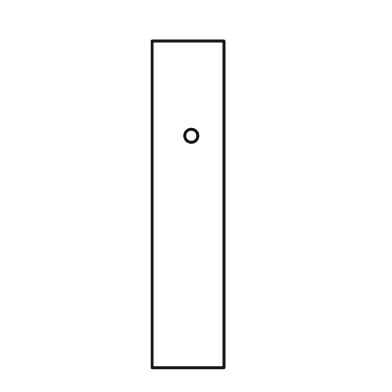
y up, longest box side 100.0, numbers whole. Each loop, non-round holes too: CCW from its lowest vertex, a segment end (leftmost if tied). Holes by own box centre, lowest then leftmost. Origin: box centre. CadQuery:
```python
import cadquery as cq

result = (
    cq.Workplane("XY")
    .moveTo(-11.0, -50.0)
    .lineTo(11.0, -50.0)
    .lineTo(11.0, 50.0)
    .lineTo(-11.0, 50.0)
    .close()
    .moveTo(1.0, 21.0)
    .circle(2.0)
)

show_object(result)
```